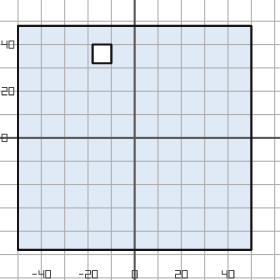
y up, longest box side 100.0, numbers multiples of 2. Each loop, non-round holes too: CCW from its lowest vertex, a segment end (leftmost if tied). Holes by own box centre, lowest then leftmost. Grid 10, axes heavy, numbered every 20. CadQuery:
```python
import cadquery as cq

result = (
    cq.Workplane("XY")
    .moveTo(-50.0, -48.0)
    .lineTo(50.0, -48.0)
    .lineTo(50.0, 48.0)
    .lineTo(-50.0, 48.0)
    .close()
    .moveTo(-18.0, 32.0)
    .lineTo(-10.0, 32.0)
    .lineTo(-10.0, 40.0)
    .lineTo(-18.0, 40.0)
    .close()
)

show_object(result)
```